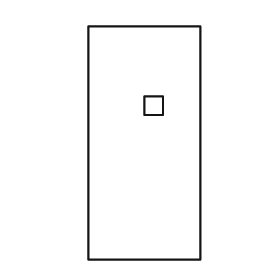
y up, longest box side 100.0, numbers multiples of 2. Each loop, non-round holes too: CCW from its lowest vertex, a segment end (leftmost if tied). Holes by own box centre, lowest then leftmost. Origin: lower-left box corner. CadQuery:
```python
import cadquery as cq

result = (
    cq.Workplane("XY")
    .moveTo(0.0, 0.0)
    .lineTo(48.0, 0.0)
    .lineTo(48.0, 100.0)
    .lineTo(0.0, 100.0)
    .close()
    .moveTo(24.0, 62.0)
    .lineTo(32.0, 62.0)
    .lineTo(32.0, 70.0)
    .lineTo(24.0, 70.0)
    .close()
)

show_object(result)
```